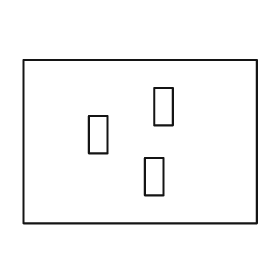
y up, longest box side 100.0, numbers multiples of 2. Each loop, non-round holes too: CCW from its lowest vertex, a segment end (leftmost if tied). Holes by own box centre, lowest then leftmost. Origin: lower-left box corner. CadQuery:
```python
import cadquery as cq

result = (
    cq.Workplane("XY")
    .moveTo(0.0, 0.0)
    .lineTo(100.0, 0.0)
    .lineTo(100.0, 70.0)
    .lineTo(0.0, 70.0)
    .close()
    .moveTo(52.0, 12.0)
    .lineTo(60.0, 12.0)
    .lineTo(60.0, 28.0)
    .lineTo(52.0, 28.0)
    .close()
    .moveTo(28.0, 30.0)
    .lineTo(36.0, 30.0)
    .lineTo(36.0, 46.0)
    .lineTo(28.0, 46.0)
    .close()
    .moveTo(56.0, 42.0)
    .lineTo(64.0, 42.0)
    .lineTo(64.0, 58.0)
    .lineTo(56.0, 58.0)
    .close()
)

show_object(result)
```